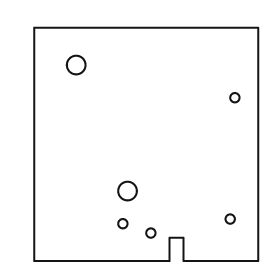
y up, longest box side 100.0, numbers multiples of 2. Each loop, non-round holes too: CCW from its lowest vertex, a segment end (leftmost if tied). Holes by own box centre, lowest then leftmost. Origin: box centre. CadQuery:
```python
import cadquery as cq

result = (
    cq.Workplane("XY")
    .moveTo(-48.0, -50.0)
    .lineTo(10.0, -50.0)
    .lineTo(10.0, -40.0)
    .lineTo(16.0, -40.0)
    .lineTo(16.0, -50.0)
    .lineTo(48.0, -50.0)
    .lineTo(48.0, 50.0)
    .lineTo(-48.0, 50.0)
    .close()
    .moveTo(2.0, -38.0)
    .circle(2.0)
    .moveTo(-10.0, -34.0)
    .circle(2.0)
    .moveTo(36.0, -32.0)
    .circle(2.0)
    .moveTo(-8.0, -20.0)
    .circle(4.0)
    .moveTo(38.0, 20.0)
    .circle(2.0)
    .moveTo(-30.0, 34.0)
    .circle(4.0)
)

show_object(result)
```